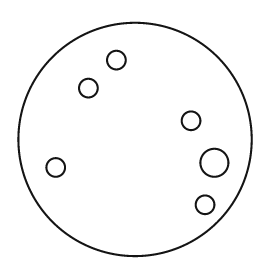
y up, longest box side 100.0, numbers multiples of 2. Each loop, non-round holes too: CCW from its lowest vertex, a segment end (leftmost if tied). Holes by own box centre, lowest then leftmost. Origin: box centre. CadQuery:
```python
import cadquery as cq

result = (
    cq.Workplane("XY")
    .moveTo(0.0, 0.0)
    .circle(50.0)
    .moveTo(30.0, -28.0)
    .circle(4.0)
    .moveTo(-34.0, -12.0)
    .circle(4.0)
    .moveTo(34.0, -10.0)
    .circle(6.0)
    .moveTo(24.0, 8.0)
    .circle(4.0)
    .moveTo(-20.0, 22.0)
    .circle(4.0)
    .moveTo(-8.0, 34.0)
    .circle(4.0)
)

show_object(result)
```